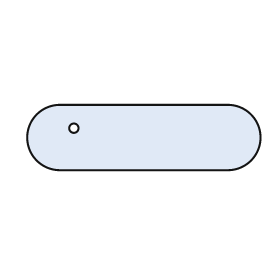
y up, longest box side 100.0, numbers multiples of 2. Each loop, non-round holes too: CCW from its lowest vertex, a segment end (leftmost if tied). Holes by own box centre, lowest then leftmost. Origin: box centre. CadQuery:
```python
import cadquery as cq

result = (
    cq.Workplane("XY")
    .moveTo(-36.0, -14.0)
    .lineTo(36.0, -14.0)
    .threePointArc((50.0, 0.0), (36.0, 14.0))
    .lineTo(-36.0, 14.0)
    .threePointArc((-50.0, 0.0), (-36.0, -14.0))
    .close()
    .moveTo(-30.0, 4.0)
    .circle(2.0)
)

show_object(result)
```